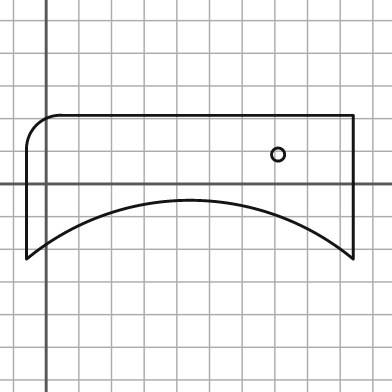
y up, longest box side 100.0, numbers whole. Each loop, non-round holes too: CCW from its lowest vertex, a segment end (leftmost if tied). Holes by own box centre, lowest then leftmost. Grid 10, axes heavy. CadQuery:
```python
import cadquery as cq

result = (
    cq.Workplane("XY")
    .moveTo(-6.0, -23.0)
    .threePointArc((44.0, -5.0), (94.0, -23.0))
    .lineTo(94.0, 21.0)
    .lineTo(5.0, 21.0)
    .threePointArc((-3.0, 18.0), (-6.0, 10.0))
    .close()
    .moveTo(71.0, 9.0)
    .circle(2.0)
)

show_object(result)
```